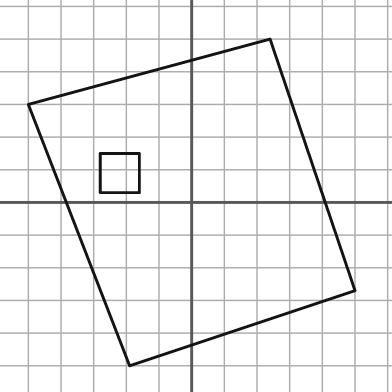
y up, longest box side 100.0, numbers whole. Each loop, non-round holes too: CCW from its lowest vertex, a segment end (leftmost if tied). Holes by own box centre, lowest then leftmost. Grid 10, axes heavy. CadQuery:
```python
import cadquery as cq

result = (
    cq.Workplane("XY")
    .moveTo(-19.0, -50.0)
    .lineTo(50.0, -27.0)
    .lineTo(24.0, 50.0)
    .lineTo(-50.0, 30.0)
    .close()
    .moveTo(-28.0, 3.0)
    .lineTo(-16.0, 3.0)
    .lineTo(-16.0, 15.0)
    .lineTo(-28.0, 15.0)
    .close()
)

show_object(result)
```